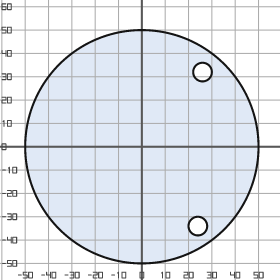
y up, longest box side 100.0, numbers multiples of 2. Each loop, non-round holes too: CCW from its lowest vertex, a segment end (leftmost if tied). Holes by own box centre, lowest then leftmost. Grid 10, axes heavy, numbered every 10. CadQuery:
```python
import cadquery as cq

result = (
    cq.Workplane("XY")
    .moveTo(0.0, 0.0)
    .circle(50.0)
    .moveTo(24.0, -34.0)
    .circle(4.0)
    .moveTo(26.0, 32.0)
    .circle(4.0)
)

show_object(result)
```